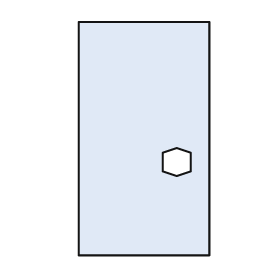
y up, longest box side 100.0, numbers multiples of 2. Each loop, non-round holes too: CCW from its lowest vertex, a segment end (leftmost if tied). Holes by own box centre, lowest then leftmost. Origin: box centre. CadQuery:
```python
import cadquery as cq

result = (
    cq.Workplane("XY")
    .moveTo(-28.0, -50.0)
    .lineTo(28.0, -50.0)
    .lineTo(28.0, 50.0)
    .lineTo(-28.0, 50.0)
    .close()
    .moveTo(14.0, -16.0)
    .lineTo(20.0, -14.0)
    .lineTo(20.0, -6.0)
    .lineTo(14.0, -4.0)
    .lineTo(8.0, -6.0)
    .lineTo(8.0, -14.0)
    .close()
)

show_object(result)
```